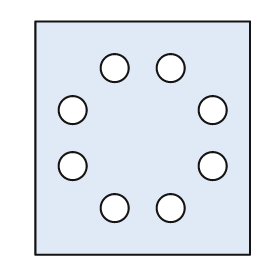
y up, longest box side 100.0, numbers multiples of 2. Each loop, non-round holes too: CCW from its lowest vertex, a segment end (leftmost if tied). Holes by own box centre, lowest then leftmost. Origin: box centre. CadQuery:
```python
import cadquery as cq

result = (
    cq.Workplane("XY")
    .moveTo(-46.0, -50.0)
    .lineTo(46.0, -50.0)
    .lineTo(46.0, 50.0)
    .lineTo(-46.0, 50.0)
    .close()
    .moveTo(-12.0, -30.0)
    .circle(6.0)
    .moveTo(12.0, -30.0)
    .circle(6.0)
    .moveTo(-30.0, -12.0)
    .circle(6.0)
    .moveTo(30.0, -12.0)
    .circle(6.0)
    .moveTo(-30.0, 12.0)
    .circle(6.0)
    .moveTo(30.0, 12.0)
    .circle(6.0)
    .moveTo(-12.0, 30.0)
    .circle(6.0)
    .moveTo(12.0, 30.0)
    .circle(6.0)
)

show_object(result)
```